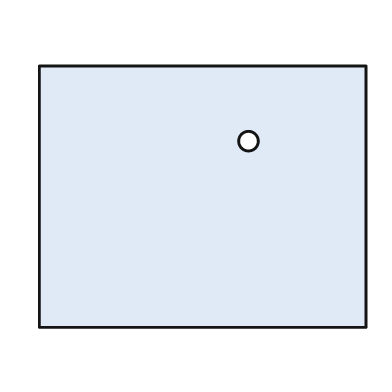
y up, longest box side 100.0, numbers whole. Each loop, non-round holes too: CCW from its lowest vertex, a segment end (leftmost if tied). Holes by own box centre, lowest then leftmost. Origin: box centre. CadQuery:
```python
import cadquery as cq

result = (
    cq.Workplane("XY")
    .moveTo(-50.0, -40.0)
    .lineTo(50.0, -40.0)
    .lineTo(50.0, 40.0)
    .lineTo(-50.0, 40.0)
    .close()
    .moveTo(14.0, 17.0)
    .circle(3.0)
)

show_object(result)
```